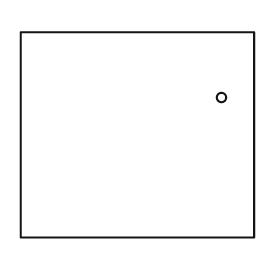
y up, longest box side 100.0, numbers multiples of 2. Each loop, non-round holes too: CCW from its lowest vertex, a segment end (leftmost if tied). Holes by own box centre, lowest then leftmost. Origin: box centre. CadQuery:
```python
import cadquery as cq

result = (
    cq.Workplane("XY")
    .moveTo(-50.0, -44.0)
    .lineTo(50.0, -44.0)
    .lineTo(50.0, 44.0)
    .lineTo(-50.0, 44.0)
    .close()
    .moveTo(36.0, 16.0)
    .circle(2.0)
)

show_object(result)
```